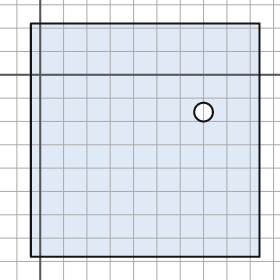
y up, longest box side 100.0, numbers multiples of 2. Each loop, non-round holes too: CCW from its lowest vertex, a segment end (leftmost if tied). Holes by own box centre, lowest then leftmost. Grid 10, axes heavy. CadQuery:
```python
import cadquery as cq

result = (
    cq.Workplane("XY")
    .moveTo(-4.0, -78.0)
    .lineTo(94.0, -78.0)
    .lineTo(94.0, 22.0)
    .lineTo(-4.0, 22.0)
    .close()
    .moveTo(70.0, -16.0)
    .circle(4.0)
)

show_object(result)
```